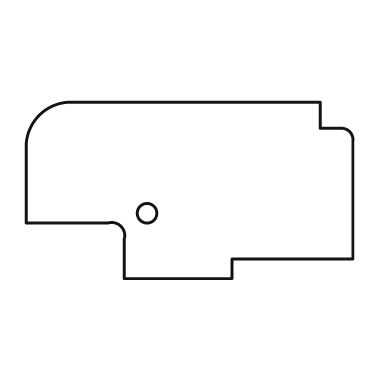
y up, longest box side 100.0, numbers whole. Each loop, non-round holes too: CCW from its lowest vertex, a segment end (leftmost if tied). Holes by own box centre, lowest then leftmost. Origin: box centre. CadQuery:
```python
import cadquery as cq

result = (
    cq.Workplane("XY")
    .moveTo(-20.0, -27.0)
    .lineTo(13.0, -27.0)
    .lineTo(13.0, -21.0)
    .lineTo(50.0, -21.0)
    .lineTo(50.0, 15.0)
    .threePointArc((49.0, 18.0), (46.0, 19.0))
    .lineTo(40.0, 19.0)
    .lineTo(40.0, 27.0)
    .lineTo(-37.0, 27.0)
    .threePointArc((-46.0, 23.0), (-50.0, 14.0))
    .lineTo(-50.0, -10.0)
    .lineTo(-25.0, -10.0)
    .threePointArc((-21.0, -11.0), (-20.0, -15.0))
    .close()
    .moveTo(-13.0, -7.0)
    .circle(3.0)
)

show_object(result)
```